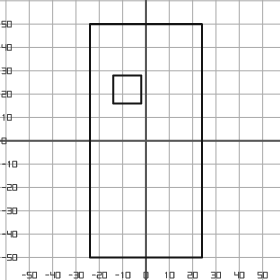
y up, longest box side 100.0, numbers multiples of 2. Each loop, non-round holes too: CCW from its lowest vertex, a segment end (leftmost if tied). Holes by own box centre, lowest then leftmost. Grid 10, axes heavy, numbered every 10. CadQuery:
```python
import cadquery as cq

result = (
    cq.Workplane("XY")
    .moveTo(-24.0, -50.0)
    .lineTo(24.0, -50.0)
    .lineTo(24.0, 50.0)
    .lineTo(-24.0, 50.0)
    .close()
    .moveTo(-14.0, 16.0)
    .lineTo(-2.0, 16.0)
    .lineTo(-2.0, 28.0)
    .lineTo(-14.0, 28.0)
    .close()
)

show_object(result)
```